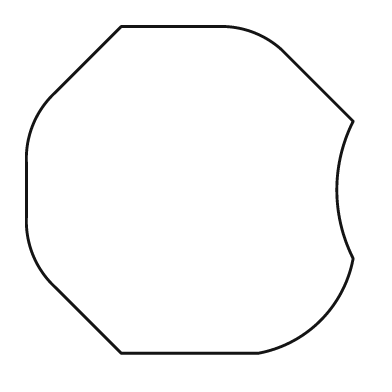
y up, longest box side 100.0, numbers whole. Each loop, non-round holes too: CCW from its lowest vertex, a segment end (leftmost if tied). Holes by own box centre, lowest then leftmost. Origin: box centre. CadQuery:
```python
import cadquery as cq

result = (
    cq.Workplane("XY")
    .moveTo(-21.0, -50.0)
    .lineTo(21.0, -50.0)
    .threePointArc((40.0, -40.0), (50.0, -21.0))
    .threePointArc((45.0, 0.0), (50.0, 21.0))
    .lineTo(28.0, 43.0)
    .threePointArc((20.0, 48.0), (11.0, 50.0))
    .lineTo(-21.0, 50.0)
    .lineTo(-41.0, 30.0)
    .threePointArc((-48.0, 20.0), (-50.0, 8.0))
    .lineTo(-50.0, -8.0)
    .threePointArc((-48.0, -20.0), (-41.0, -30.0))
    .close()
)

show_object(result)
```